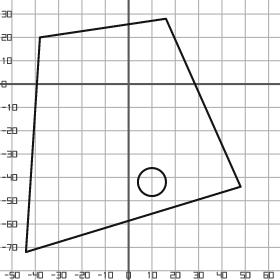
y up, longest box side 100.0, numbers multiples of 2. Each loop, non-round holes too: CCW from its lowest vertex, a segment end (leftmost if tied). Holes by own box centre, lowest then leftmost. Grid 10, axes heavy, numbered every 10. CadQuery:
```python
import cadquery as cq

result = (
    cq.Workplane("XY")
    .moveTo(-44.0, -72.0)
    .lineTo(48.0, -44.0)
    .lineTo(16.0, 28.0)
    .lineTo(-38.0, 20.0)
    .close()
    .moveTo(10.0, -42.0)
    .circle(6.0)
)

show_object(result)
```